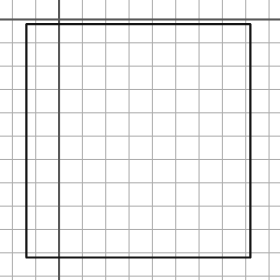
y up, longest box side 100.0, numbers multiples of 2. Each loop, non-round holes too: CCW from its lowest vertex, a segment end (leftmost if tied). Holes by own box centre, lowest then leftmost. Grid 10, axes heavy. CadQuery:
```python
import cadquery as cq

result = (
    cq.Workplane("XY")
    .moveTo(-14.0, -102.0)
    .lineTo(82.0, -102.0)
    .lineTo(82.0, -2.0)
    .lineTo(-14.0, -2.0)
    .close()
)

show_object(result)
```